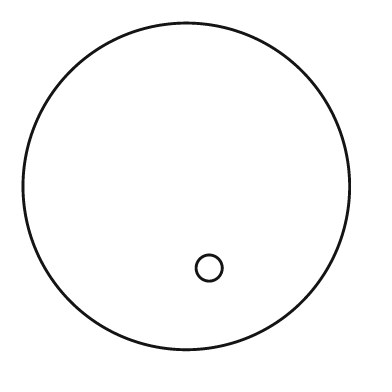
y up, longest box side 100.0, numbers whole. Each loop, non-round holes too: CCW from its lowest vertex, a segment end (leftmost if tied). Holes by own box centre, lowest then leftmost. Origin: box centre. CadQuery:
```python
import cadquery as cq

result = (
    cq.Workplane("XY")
    .moveTo(0.0, 0.0)
    .circle(50.0)
    .moveTo(7.0, -25.0)
    .circle(4.0)
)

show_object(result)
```